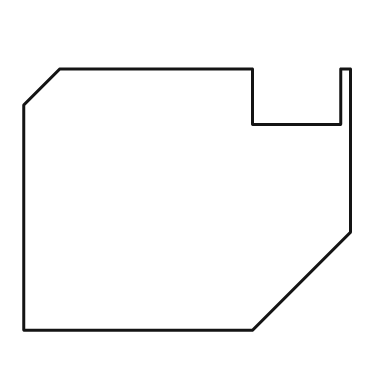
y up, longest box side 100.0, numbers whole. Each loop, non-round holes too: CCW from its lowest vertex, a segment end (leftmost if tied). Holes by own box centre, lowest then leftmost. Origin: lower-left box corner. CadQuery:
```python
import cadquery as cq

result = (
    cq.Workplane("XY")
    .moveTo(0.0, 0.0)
    .lineTo(70.0, 0.0)
    .lineTo(100.0, 30.0)
    .lineTo(100.0, 80.0)
    .lineTo(97.0, 80.0)
    .lineTo(97.0, 63.0)
    .lineTo(70.0, 63.0)
    .lineTo(70.0, 80.0)
    .lineTo(11.0, 80.0)
    .lineTo(0.0, 69.0)
    .close()
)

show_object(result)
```